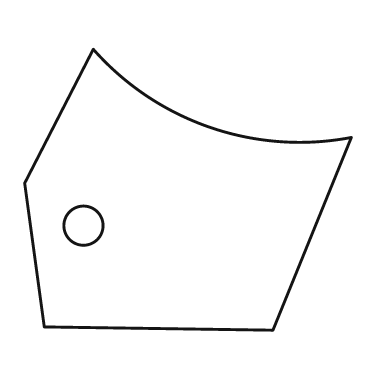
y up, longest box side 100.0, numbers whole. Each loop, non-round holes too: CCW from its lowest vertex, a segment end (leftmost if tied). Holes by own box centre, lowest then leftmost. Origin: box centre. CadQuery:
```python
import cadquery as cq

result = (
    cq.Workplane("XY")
    .moveTo(26.0, -43.0)
    .lineTo(50.0, 16.0)
    .threePointArc((7.0, 19.0), (-29.0, 43.0))
    .lineTo(-50.0, 2.0)
    .lineTo(-44.0, -42.0)
    .close()
    .moveTo(-32.0, -11.0)
    .circle(6.0)
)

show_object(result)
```